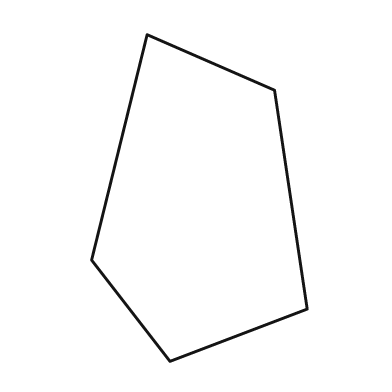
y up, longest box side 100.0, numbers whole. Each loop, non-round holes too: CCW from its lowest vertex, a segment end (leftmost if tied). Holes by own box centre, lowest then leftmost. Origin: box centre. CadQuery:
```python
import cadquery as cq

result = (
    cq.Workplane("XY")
    .moveTo(-9.0, -50.0)
    .lineTo(33.0, -34.0)
    .lineTo(23.0, 33.0)
    .lineTo(-16.0, 50.0)
    .lineTo(-33.0, -19.0)
    .close()
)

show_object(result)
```